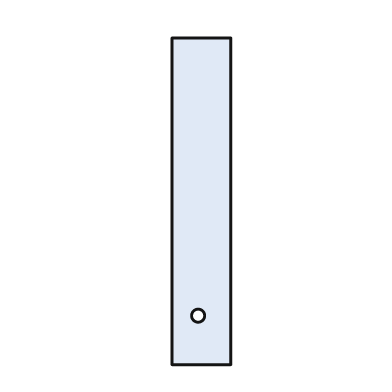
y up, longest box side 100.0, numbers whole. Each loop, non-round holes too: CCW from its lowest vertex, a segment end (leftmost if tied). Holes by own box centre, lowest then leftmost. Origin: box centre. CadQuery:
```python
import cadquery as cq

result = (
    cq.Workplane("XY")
    .moveTo(-9.0, -50.0)
    .lineTo(9.0, -50.0)
    .lineTo(9.0, 50.0)
    .lineTo(-9.0, 50.0)
    .close()
    .moveTo(-1.0, -35.0)
    .circle(2.0)
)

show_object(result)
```